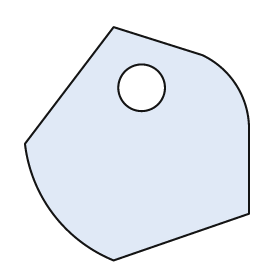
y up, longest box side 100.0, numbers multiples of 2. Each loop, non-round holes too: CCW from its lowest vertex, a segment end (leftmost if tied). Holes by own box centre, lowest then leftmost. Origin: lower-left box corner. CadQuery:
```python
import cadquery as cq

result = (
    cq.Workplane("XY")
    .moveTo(38.0, 0.0)
    .lineTo(96.0, 20.0)
    .lineTo(96.0, 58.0)
    .threePointArc((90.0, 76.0), (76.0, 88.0))
    .lineTo(38.0, 100.0)
    .lineTo(0.0, 50.0)
    .threePointArc((12.0, 20.0), (38.0, 0.0))
    .close()
    .moveTo(50.0, 74.0)
    .circle(10.0)
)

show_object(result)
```